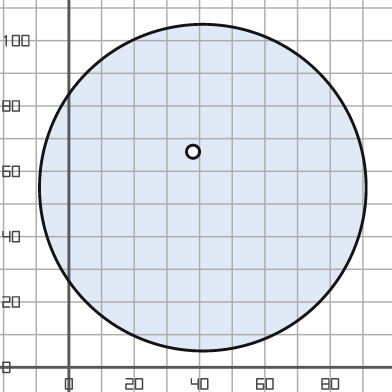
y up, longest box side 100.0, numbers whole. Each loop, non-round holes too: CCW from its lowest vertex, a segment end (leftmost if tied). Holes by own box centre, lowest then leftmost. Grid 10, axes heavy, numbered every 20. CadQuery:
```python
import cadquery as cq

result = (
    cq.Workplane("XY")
    .moveTo(41.0, 55.0)
    .circle(50.0)
    .moveTo(38.0, 66.0)
    .circle(2.0)
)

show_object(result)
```